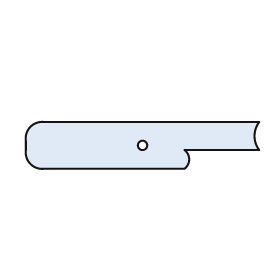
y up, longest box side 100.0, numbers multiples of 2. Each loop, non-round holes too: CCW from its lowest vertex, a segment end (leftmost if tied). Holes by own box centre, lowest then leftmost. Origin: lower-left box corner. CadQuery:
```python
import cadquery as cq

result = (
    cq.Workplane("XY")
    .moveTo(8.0, 0.0)
    .lineTo(68.0, 0.0)
    .threePointArc((70.0, 4.0), (68.0, 8.0))
    .lineTo(100.0, 8.0)
    .threePointArc((98.0, 14.0), (100.0, 20.0))
    .lineTo(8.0, 20.0)
    .threePointArc((2.0, 18.0), (0.0, 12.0))
    .lineTo(0.0, 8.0)
    .threePointArc((2.0, 2.0), (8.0, 0.0))
    .close()
    .moveTo(50.0, 10.0)
    .circle(2.0)
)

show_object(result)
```